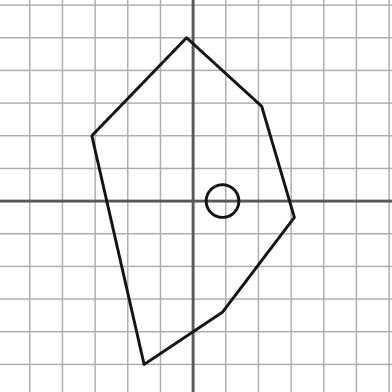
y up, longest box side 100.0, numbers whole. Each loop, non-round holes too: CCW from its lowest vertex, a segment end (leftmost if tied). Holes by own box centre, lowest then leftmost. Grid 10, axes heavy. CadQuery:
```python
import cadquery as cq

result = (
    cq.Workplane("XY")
    .moveTo(-15.0, -50.0)
    .lineTo(9.0, -34.0)
    .lineTo(31.0, -5.0)
    .lineTo(21.0, 29.0)
    .lineTo(-2.0, 50.0)
    .lineTo(-31.0, 20.0)
    .close()
    .moveTo(9.0, 0.0)
    .circle(5.0)
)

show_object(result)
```